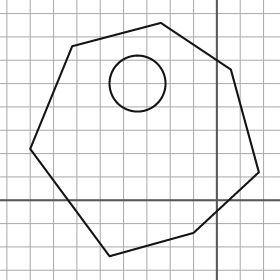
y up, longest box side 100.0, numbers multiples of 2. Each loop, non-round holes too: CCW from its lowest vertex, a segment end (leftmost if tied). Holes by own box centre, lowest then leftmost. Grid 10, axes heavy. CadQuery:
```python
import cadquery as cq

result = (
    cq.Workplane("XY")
    .moveTo(-46.0, -24.0)
    .lineTo(-10.0, -14.0)
    .lineTo(18.0, 12.0)
    .lineTo(6.0, 56.0)
    .lineTo(-24.0, 76.0)
    .lineTo(-62.0, 66.0)
    .lineTo(-80.0, 22.0)
    .close()
    .moveTo(-34.0, 50.0)
    .circle(12.0)
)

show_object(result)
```